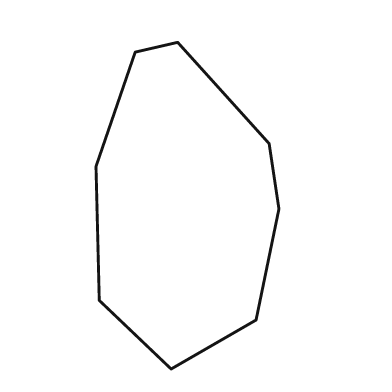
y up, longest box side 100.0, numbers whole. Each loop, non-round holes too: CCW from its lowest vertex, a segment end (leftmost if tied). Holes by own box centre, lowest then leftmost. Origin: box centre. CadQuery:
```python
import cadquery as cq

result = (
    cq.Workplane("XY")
    .moveTo(-5.0, -50.0)
    .lineTo(21.0, -35.0)
    .lineTo(28.0, -1.0)
    .lineTo(25.0, 19.0)
    .lineTo(-3.0, 50.0)
    .lineTo(-16.0, 47.0)
    .lineTo(-28.0, 12.0)
    .lineTo(-27.0, -29.0)
    .close()
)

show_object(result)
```